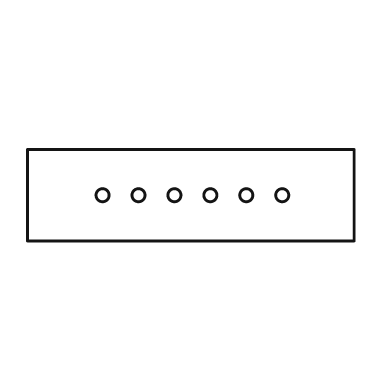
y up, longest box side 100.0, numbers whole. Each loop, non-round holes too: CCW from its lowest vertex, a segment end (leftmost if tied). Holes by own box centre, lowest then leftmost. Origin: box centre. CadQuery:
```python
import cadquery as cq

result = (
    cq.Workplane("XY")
    .moveTo(-50.0, -14.0)
    .lineTo(50.0, -14.0)
    .lineTo(50.0, 14.0)
    .lineTo(-50.0, 14.0)
    .close()
    .moveTo(-27.0, 0.0)
    .circle(2.0)
    .moveTo(-16.0, 0.0)
    .circle(2.0)
    .moveTo(-5.0, 0.0)
    .circle(2.0)
    .moveTo(6.0, 0.0)
    .circle(2.0)
    .moveTo(17.0, 0.0)
    .circle(2.0)
    .moveTo(28.0, 0.0)
    .circle(2.0)
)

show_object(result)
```